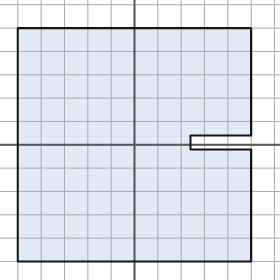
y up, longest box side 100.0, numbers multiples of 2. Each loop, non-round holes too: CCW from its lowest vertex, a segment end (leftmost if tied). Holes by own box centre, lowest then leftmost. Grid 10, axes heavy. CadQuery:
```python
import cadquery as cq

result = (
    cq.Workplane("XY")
    .moveTo(-50.0, -50.0)
    .lineTo(50.0, -50.0)
    .lineTo(50.0, -2.0)
    .lineTo(24.0, -2.0)
    .lineTo(24.0, 4.0)
    .lineTo(50.0, 4.0)
    .lineTo(50.0, 50.0)
    .lineTo(-50.0, 50.0)
    .close()
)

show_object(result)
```